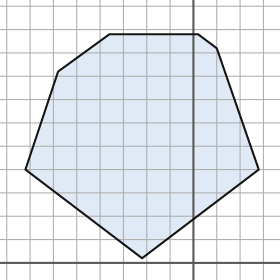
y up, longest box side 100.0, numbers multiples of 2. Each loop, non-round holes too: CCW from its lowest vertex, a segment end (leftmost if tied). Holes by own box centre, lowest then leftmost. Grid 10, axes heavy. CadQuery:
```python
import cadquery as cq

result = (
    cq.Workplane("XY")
    .moveTo(-22.0, 2.0)
    .lineTo(28.0, 40.0)
    .lineTo(10.0, 92.0)
    .lineTo(2.0, 98.0)
    .lineTo(-36.0, 98.0)
    .lineTo(-58.0, 82.0)
    .lineTo(-72.0, 40.0)
    .close()
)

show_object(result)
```